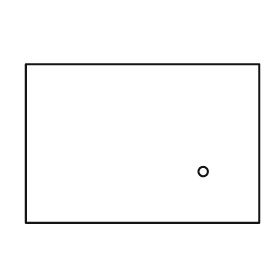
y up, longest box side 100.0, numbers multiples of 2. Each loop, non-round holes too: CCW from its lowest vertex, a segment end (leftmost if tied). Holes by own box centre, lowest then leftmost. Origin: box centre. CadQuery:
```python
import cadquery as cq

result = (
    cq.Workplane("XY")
    .moveTo(-50.0, -34.0)
    .lineTo(50.0, -34.0)
    .lineTo(50.0, 34.0)
    .lineTo(-50.0, 34.0)
    .close()
    .moveTo(26.0, -12.0)
    .circle(2.0)
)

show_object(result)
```